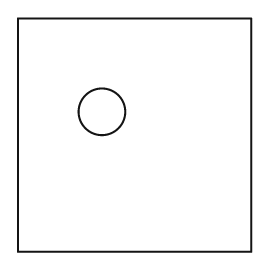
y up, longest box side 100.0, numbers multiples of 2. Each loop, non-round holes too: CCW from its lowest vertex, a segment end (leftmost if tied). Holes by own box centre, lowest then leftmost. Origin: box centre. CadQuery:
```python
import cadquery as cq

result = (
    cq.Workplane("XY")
    .moveTo(-50.0, -50.0)
    .lineTo(50.0, -50.0)
    .lineTo(50.0, 50.0)
    .lineTo(-50.0, 50.0)
    .close()
    .moveTo(-14.0, 10.0)
    .circle(10.0)
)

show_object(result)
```